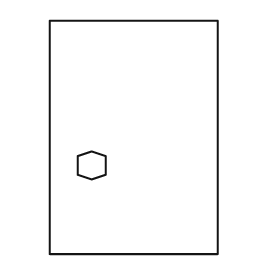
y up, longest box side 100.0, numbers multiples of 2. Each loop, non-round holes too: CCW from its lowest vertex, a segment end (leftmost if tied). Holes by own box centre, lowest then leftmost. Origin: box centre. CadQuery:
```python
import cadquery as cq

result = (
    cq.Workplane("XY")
    .moveTo(-36.0, -50.0)
    .lineTo(36.0, -50.0)
    .lineTo(36.0, 50.0)
    .lineTo(-36.0, 50.0)
    .close()
    .moveTo(-18.0, -18.0)
    .lineTo(-12.0, -16.0)
    .lineTo(-12.0, -8.0)
    .lineTo(-18.0, -6.0)
    .lineTo(-24.0, -8.0)
    .lineTo(-24.0, -16.0)
    .close()
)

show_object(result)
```